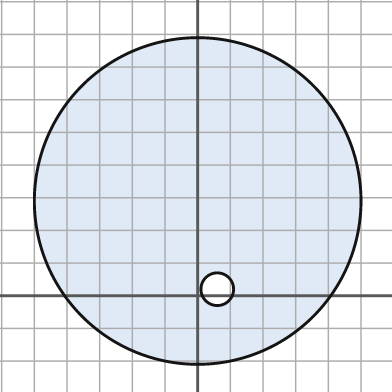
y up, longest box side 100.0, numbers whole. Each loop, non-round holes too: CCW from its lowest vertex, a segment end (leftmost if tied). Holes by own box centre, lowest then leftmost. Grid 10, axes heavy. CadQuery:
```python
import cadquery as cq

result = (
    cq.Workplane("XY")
    .moveTo(0.0, 29.0)
    .circle(50.0)
    .moveTo(6.0, 2.0)
    .circle(5.0)
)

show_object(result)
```